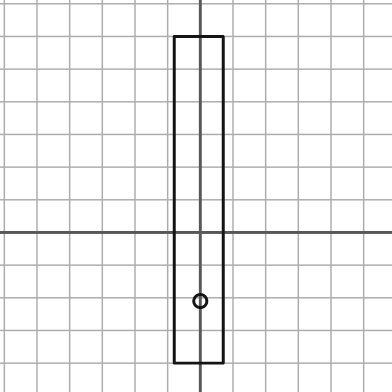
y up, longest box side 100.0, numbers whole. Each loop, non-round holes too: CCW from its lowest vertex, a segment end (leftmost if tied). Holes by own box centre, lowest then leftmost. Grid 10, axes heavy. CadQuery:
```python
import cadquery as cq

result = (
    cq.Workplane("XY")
    .moveTo(-8.0, -40.0)
    .lineTo(7.0, -40.0)
    .lineTo(7.0, 60.0)
    .lineTo(-8.0, 60.0)
    .close()
    .moveTo(0.0, -21.0)
    .circle(2.0)
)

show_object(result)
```